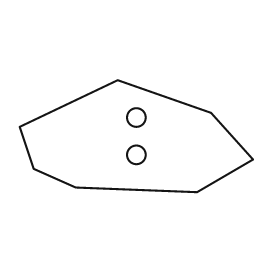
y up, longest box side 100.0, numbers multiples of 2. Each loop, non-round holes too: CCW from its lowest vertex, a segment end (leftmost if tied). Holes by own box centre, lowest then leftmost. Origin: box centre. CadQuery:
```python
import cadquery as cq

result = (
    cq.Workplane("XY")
    .moveTo(26.0, -24.0)
    .lineTo(50.0, -10.0)
    .lineTo(32.0, 10.0)
    .lineTo(-8.0, 24.0)
    .lineTo(-50.0, 4.0)
    .lineTo(-44.0, -14.0)
    .lineTo(-26.0, -22.0)
    .close()
    .moveTo(0.0, -8.0)
    .circle(4.0)
    .moveTo(0.0, 8.0)
    .circle(4.0)
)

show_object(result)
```